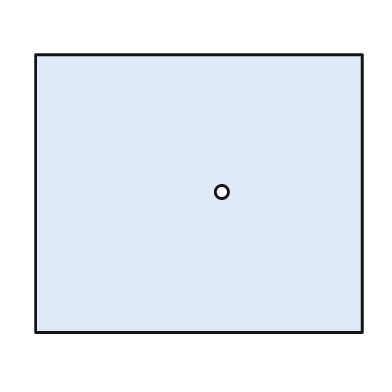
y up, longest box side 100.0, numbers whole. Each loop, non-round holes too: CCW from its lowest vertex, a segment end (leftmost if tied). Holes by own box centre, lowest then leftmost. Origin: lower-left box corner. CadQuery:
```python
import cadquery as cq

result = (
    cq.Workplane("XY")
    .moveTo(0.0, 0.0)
    .lineTo(100.0, 0.0)
    .lineTo(100.0, 85.0)
    .lineTo(0.0, 85.0)
    .close()
    .moveTo(57.0, 43.0)
    .circle(2.0)
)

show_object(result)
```